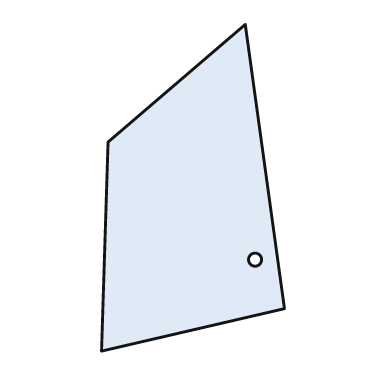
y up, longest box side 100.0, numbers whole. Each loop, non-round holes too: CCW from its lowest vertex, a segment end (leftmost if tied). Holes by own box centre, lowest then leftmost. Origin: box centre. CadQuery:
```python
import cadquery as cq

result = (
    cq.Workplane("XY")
    .moveTo(-28.0, -50.0)
    .lineTo(28.0, -37.0)
    .lineTo(16.0, 50.0)
    .lineTo(-26.0, 14.0)
    .close()
    .moveTo(19.0, -22.0)
    .circle(2.0)
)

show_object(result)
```